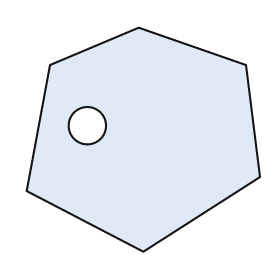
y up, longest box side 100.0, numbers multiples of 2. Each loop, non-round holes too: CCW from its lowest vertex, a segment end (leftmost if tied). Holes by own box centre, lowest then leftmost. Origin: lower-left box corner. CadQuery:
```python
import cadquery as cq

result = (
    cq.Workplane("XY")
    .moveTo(50.0, 0.0)
    .lineTo(100.0, 32.0)
    .lineTo(94.0, 80.0)
    .lineTo(48.0, 96.0)
    .lineTo(10.0, 80.0)
    .lineTo(0.0, 26.0)
    .close()
    .moveTo(26.0, 54.0)
    .circle(8.0)
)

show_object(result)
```